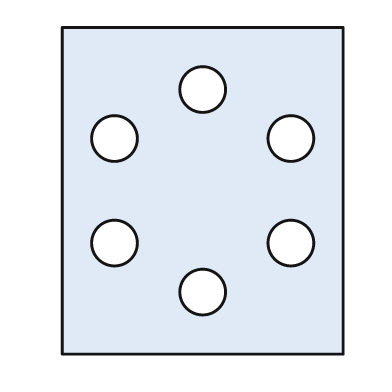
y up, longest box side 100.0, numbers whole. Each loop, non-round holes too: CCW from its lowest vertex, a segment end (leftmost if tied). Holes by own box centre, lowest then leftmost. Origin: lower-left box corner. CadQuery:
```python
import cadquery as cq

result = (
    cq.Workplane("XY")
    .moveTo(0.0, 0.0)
    .lineTo(86.0, 0.0)
    .lineTo(86.0, 100.0)
    .lineTo(0.0, 100.0)
    .close()
    .moveTo(43.0, 19.0)
    .circle(7.0)
    .moveTo(16.0, 34.0)
    .circle(7.0)
    .moveTo(70.0, 34.0)
    .circle(7.0)
    .moveTo(16.0, 66.0)
    .circle(7.0)
    .moveTo(70.0, 66.0)
    .circle(7.0)
    .moveTo(43.0, 81.0)
    .circle(7.0)
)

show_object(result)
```